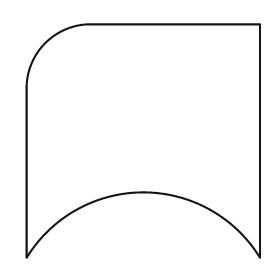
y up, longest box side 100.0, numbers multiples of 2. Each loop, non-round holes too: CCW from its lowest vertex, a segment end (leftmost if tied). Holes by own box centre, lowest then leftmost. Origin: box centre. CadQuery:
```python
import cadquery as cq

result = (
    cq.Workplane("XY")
    .moveTo(-50.0, -50.0)
    .threePointArc((0.0, -22.0), (50.0, -50.0))
    .lineTo(50.0, 50.0)
    .lineTo(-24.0, 50.0)
    .threePointArc((-42.0, 42.0), (-50.0, 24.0))
    .close()
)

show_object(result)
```